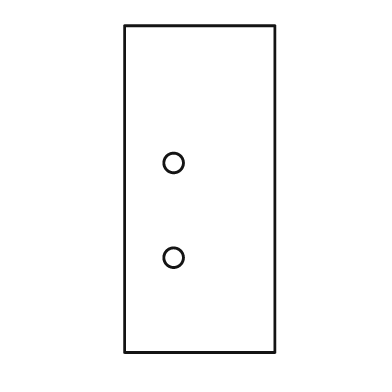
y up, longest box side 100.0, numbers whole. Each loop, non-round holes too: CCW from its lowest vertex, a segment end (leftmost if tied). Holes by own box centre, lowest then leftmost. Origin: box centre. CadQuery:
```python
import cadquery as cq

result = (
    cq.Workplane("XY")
    .moveTo(-23.0, -50.0)
    .lineTo(23.0, -50.0)
    .lineTo(23.0, 50.0)
    .lineTo(-23.0, 50.0)
    .close()
    .moveTo(-8.0, -21.0)
    .circle(3.0)
    .moveTo(-8.0, 8.0)
    .circle(3.0)
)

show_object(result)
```